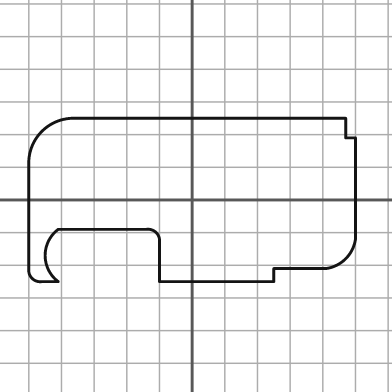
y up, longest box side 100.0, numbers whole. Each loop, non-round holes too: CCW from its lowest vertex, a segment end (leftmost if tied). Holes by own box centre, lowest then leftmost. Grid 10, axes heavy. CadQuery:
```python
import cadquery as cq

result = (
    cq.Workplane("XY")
    .moveTo(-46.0, -25.0)
    .lineTo(-41.0, -25.0)
    .threePointArc((-45.0, -17.0), (-41.0, -9.0))
    .lineTo(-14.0, -9.0)
    .threePointArc((-11.0, -10.0), (-10.0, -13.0))
    .lineTo(-10.0, -25.0)
    .lineTo(25.0, -25.0)
    .lineTo(25.0, -21.0)
    .lineTo(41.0, -21.0)
    .threePointArc((47.0, -18.0), (50.0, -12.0))
    .lineTo(50.0, 19.0)
    .lineTo(47.0, 19.0)
    .lineTo(47.0, 25.0)
    .lineTo(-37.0, 25.0)
    .threePointArc((-46.0, 21.0), (-50.0, 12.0))
    .lineTo(-50.0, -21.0)
    .threePointArc((-49.0, -24.0), (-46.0, -25.0))
    .close()
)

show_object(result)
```